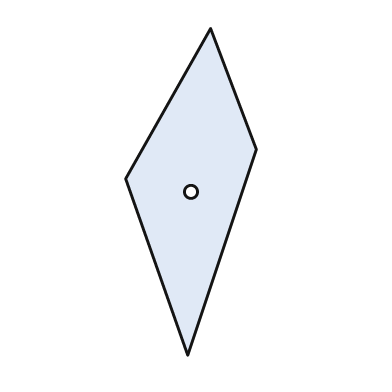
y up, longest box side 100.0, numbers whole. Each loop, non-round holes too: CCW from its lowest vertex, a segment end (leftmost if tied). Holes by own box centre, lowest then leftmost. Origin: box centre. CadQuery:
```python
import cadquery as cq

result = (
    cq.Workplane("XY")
    .moveTo(-1.0, -50.0)
    .lineTo(20.0, 13.0)
    .lineTo(6.0, 50.0)
    .lineTo(-20.0, 4.0)
    .close()
    .moveTo(0.0, 0.0)
    .circle(2.0)
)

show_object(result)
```